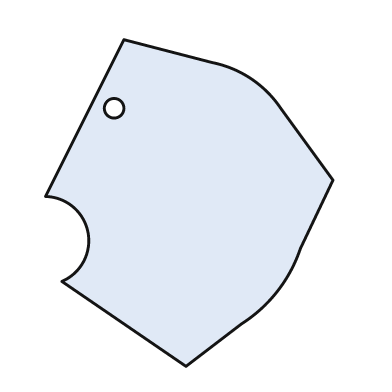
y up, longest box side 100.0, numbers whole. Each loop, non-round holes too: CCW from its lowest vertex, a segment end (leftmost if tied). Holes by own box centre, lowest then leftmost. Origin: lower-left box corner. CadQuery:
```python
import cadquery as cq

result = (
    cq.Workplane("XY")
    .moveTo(43.0, 0.0)
    .lineTo(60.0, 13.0)
    .threePointArc((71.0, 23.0), (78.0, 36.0))
    .lineTo(88.0, 57.0)
    .lineTo(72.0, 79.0)
    .threePointArc((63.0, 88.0), (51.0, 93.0))
    .lineTo(24.0, 100.0)
    .lineTo(0.0, 52.0)
    .threePointArc((13.0, 41.0), (5.0, 26.0))
    .close()
    .moveTo(21.0, 79.0)
    .circle(3.0)
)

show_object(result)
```